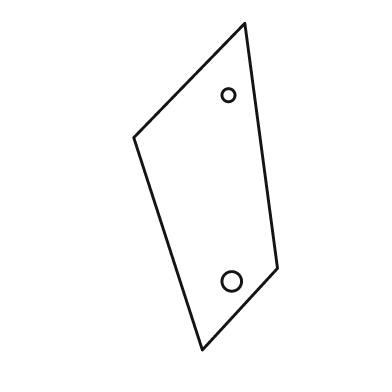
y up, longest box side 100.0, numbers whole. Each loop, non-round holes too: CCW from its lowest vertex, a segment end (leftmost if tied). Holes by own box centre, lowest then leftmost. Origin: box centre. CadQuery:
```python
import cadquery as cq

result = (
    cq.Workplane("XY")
    .moveTo(-1.0, -50.0)
    .lineTo(22.0, -25.0)
    .lineTo(12.0, 50.0)
    .lineTo(-22.0, 15.0)
    .close()
    .moveTo(8.0, -29.0)
    .circle(3.0)
    .moveTo(7.0, 28.0)
    .circle(2.0)
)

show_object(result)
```